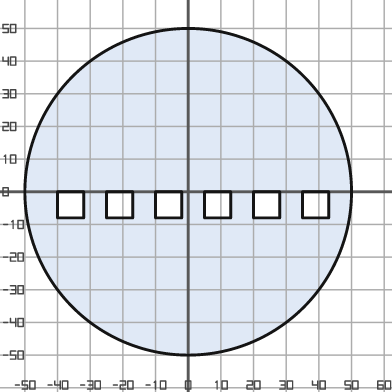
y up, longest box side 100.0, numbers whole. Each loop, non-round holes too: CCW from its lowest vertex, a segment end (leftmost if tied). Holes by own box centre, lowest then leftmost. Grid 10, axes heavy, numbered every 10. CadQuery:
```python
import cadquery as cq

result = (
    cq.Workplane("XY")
    .moveTo(0.0, 0.0)
    .circle(50.0)
    .moveTo(-40.0, -8.0)
    .lineTo(-32.0, -8.0)
    .lineTo(-32.0, 0.0)
    .lineTo(-40.0, 0.0)
    .close()
    .moveTo(-25.0, -8.0)
    .lineTo(-17.0, -8.0)
    .lineTo(-17.0, 0.0)
    .lineTo(-25.0, 0.0)
    .close()
    .moveTo(-10.0, -8.0)
    .lineTo(-2.0, -8.0)
    .lineTo(-2.0, 0.0)
    .lineTo(-10.0, 0.0)
    .close()
    .moveTo(5.0, -8.0)
    .lineTo(13.0, -8.0)
    .lineTo(13.0, 0.0)
    .lineTo(5.0, 0.0)
    .close()
    .moveTo(20.0, -8.0)
    .lineTo(28.0, -8.0)
    .lineTo(28.0, 0.0)
    .lineTo(20.0, 0.0)
    .close()
    .moveTo(35.0, -8.0)
    .lineTo(43.0, -8.0)
    .lineTo(43.0, 0.0)
    .lineTo(35.0, 0.0)
    .close()
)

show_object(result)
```